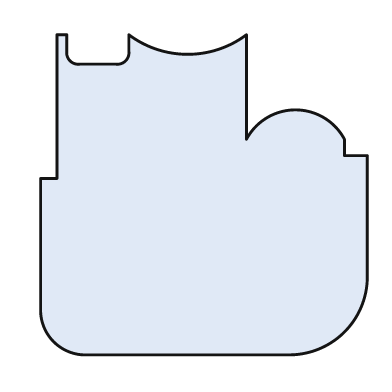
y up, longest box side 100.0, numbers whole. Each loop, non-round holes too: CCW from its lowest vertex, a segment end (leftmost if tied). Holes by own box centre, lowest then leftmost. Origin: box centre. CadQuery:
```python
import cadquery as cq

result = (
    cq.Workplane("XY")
    .moveTo(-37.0, -49.0)
    .lineTo(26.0, -49.0)
    .threePointArc((43.0, -42.0), (50.0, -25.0))
    .lineTo(50.0, 12.0)
    .lineTo(43.0, 12.0)
    .lineTo(43.0, 17.0)
    .threePointArc((28.0, 26.0), (13.0, 17.0))
    .lineTo(13.0, 49.0)
    .threePointArc((-5.0, 43.0), (-23.0, 49.0))
    .lineTo(-23.0, 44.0)
    .threePointArc((-24.0, 41.0), (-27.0, 40.0))
    .lineTo(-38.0, 40.0)
    .threePointArc((-41.0, 41.0), (-42.0, 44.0))
    .lineTo(-42.0, 49.0)
    .lineTo(-45.0, 49.0)
    .lineTo(-45.0, 5.0)
    .lineTo(-50.0, 5.0)
    .lineTo(-50.0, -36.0)
    .threePointArc((-46.0, -45.0), (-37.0, -49.0))
    .close()
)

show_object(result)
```